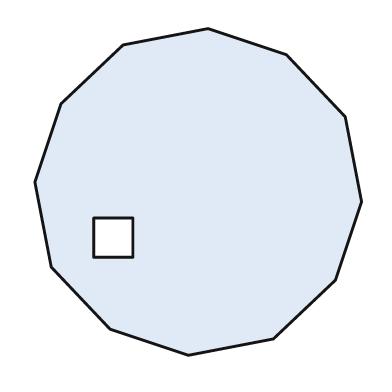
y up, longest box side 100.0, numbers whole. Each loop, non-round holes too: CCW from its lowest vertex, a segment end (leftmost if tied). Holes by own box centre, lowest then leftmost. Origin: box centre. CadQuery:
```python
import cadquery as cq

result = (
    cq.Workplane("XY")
    .moveTo(-3.0, -50.0)
    .lineTo(23.0, -45.0)
    .lineTo(42.0, -27.0)
    .lineTo(50.0, -3.0)
    .lineTo(45.0, 23.0)
    .lineTo(27.0, 42.0)
    .lineTo(3.0, 50.0)
    .lineTo(-23.0, 45.0)
    .lineTo(-42.0, 27.0)
    .lineTo(-50.0, 3.0)
    .lineTo(-45.0, -23.0)
    .lineTo(-27.0, -42.0)
    .close()
    .moveTo(-32.0, -20.0)
    .lineTo(-20.0, -20.0)
    .lineTo(-20.0, -8.0)
    .lineTo(-32.0, -8.0)
    .close()
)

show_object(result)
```